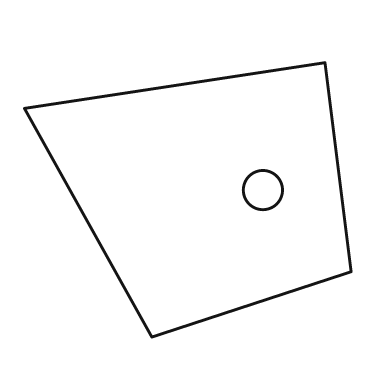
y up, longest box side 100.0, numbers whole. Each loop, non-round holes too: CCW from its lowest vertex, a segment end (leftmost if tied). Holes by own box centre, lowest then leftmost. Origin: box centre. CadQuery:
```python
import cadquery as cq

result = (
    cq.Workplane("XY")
    .moveTo(-11.0, -42.0)
    .lineTo(50.0, -22.0)
    .lineTo(42.0, 42.0)
    .lineTo(-50.0, 28.0)
    .close()
    .moveTo(23.0, 3.0)
    .circle(6.0)
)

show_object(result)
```